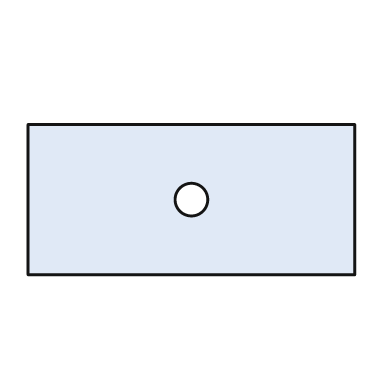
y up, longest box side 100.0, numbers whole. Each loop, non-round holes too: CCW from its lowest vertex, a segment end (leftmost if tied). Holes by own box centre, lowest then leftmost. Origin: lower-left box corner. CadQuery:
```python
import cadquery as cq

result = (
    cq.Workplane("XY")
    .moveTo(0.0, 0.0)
    .lineTo(100.0, 0.0)
    .lineTo(100.0, 46.0)
    .lineTo(0.0, 46.0)
    .close()
    .moveTo(50.0, 23.0)
    .circle(5.0)
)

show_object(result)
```